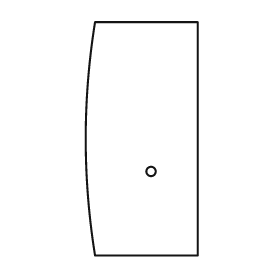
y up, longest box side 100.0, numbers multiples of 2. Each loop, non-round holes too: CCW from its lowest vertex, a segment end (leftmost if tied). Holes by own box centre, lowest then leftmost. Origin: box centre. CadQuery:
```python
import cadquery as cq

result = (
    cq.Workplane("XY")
    .moveTo(-20.0, -50.0)
    .lineTo(24.0, -50.0)
    .lineTo(24.0, 50.0)
    .lineTo(-20.0, 50.0)
    .threePointArc((-24.0, 0.0), (-20.0, -50.0))
    .close()
    .moveTo(4.0, -14.0)
    .circle(2.0)
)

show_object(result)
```